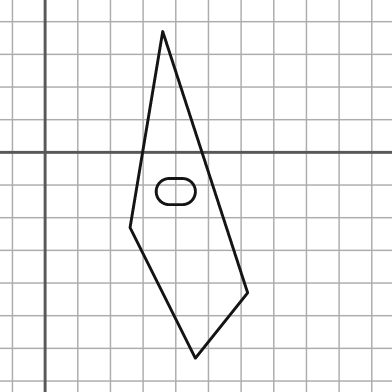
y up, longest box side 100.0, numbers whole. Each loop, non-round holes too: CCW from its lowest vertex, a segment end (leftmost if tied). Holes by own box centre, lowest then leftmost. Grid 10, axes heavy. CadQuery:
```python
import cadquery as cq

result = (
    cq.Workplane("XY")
    .moveTo(46.0, -63.0)
    .lineTo(62.0, -43.0)
    .lineTo(36.0, 37.0)
    .lineTo(26.0, -23.0)
    .close()
    .moveTo(38.0, -16.0)
    .lineTo(42.0, -16.0)
    .threePointArc((46.0, -12.0), (42.0, -8.0))
    .lineTo(38.0, -8.0)
    .threePointArc((34.0, -12.0), (38.0, -16.0))
    .close()
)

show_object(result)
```